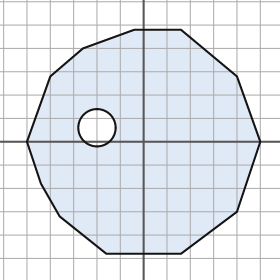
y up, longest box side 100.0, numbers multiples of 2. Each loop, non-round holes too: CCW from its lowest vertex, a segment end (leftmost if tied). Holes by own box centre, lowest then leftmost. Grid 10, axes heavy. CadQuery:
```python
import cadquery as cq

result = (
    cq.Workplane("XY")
    .moveTo(-16.0, -48.0)
    .lineTo(16.0, -48.0)
    .lineTo(40.0, -30.0)
    .lineTo(50.0, 0.0)
    .lineTo(40.0, 28.0)
    .lineTo(16.0, 48.0)
    .lineTo(-4.0, 48.0)
    .lineTo(-26.0, 40.0)
    .lineTo(-40.0, 28.0)
    .lineTo(-50.0, 0.0)
    .lineTo(-44.0, -18.0)
    .lineTo(-36.0, -32.0)
    .close()
    .moveTo(-20.0, 6.0)
    .circle(8.0)
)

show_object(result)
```